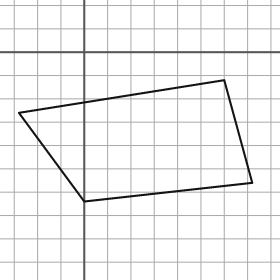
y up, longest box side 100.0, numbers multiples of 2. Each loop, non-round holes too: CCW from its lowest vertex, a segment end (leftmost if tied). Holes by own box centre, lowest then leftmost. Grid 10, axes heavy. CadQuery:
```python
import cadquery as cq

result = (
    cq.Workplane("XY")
    .moveTo(0.0, -64.0)
    .lineTo(72.0, -56.0)
    .lineTo(60.0, -12.0)
    .lineTo(-28.0, -26.0)
    .close()
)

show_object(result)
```